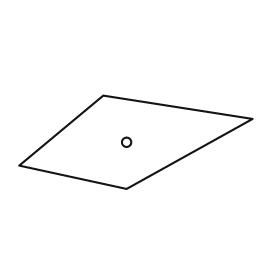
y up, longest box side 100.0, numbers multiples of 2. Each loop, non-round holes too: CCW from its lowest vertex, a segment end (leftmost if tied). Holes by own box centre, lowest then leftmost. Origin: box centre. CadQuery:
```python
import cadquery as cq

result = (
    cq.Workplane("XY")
    .moveTo(-4.0, -20.0)
    .lineTo(50.0, 10.0)
    .lineTo(-14.0, 20.0)
    .lineTo(-50.0, -10.0)
    .close()
    .moveTo(-4.0, 0.0)
    .circle(2.0)
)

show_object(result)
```